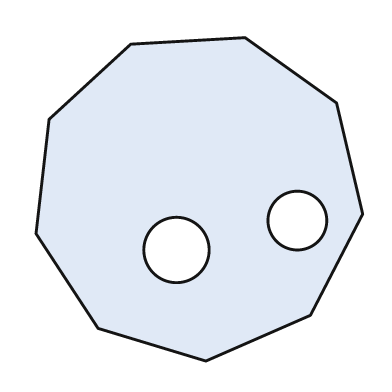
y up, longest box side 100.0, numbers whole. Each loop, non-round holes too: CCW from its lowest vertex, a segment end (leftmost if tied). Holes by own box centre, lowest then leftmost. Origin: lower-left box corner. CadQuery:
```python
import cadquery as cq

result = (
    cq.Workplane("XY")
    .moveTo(52.0, 0.0)
    .lineTo(84.0, 14.0)
    .lineTo(100.0, 45.0)
    .lineTo(92.0, 79.0)
    .lineTo(64.0, 99.0)
    .lineTo(29.0, 97.0)
    .lineTo(4.0, 74.0)
    .lineTo(0.0, 39.0)
    .lineTo(19.0, 10.0)
    .close()
    .moveTo(43.0, 34.0)
    .circle(10.0)
    .moveTo(80.0, 43.0)
    .circle(9.0)
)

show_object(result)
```